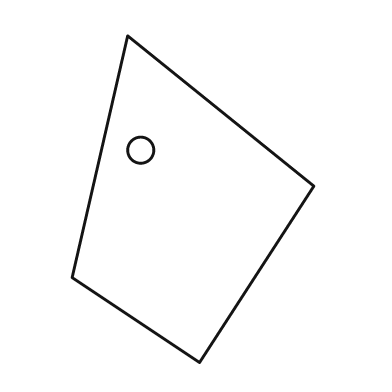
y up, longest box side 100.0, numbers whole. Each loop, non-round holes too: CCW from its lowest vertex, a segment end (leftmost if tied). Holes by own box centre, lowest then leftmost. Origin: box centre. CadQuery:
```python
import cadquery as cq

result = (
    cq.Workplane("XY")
    .moveTo(2.0, -50.0)
    .lineTo(37.0, 4.0)
    .lineTo(-20.0, 50.0)
    .lineTo(-37.0, -24.0)
    .close()
    .moveTo(-16.0, 15.0)
    .circle(4.0)
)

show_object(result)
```